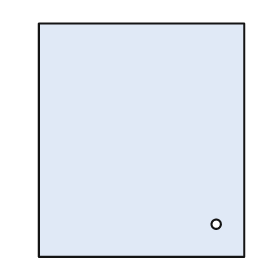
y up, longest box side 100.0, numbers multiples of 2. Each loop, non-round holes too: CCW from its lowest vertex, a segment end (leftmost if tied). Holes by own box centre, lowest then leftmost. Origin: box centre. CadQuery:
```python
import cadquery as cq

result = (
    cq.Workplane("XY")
    .moveTo(-44.0, -50.0)
    .lineTo(44.0, -50.0)
    .lineTo(44.0, 50.0)
    .lineTo(-44.0, 50.0)
    .close()
    .moveTo(32.0, -36.0)
    .circle(2.0)
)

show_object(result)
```